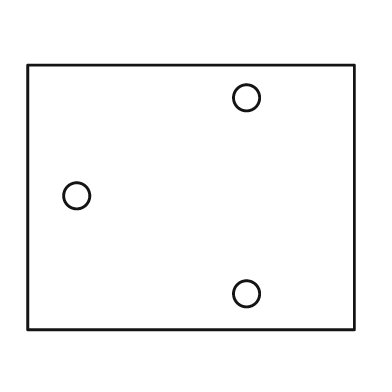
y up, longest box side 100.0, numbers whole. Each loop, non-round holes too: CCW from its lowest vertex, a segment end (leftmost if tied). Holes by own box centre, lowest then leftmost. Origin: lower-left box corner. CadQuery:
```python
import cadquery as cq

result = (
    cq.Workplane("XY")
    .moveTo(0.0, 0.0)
    .lineTo(100.0, 0.0)
    .lineTo(100.0, 81.0)
    .lineTo(0.0, 81.0)
    .close()
    .moveTo(67.0, 11.0)
    .circle(4.0)
    .moveTo(15.0, 41.0)
    .circle(4.0)
    .moveTo(67.0, 71.0)
    .circle(4.0)
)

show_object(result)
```